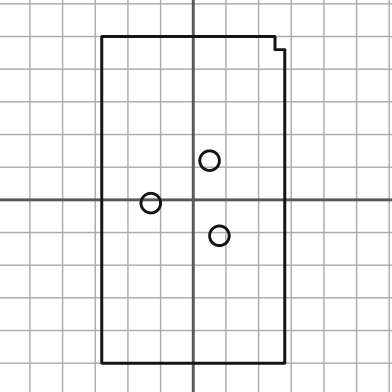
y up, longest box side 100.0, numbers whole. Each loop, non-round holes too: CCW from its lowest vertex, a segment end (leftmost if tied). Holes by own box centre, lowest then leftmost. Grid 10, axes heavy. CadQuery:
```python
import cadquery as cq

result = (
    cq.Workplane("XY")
    .moveTo(-28.0, -50.0)
    .lineTo(28.0, -50.0)
    .lineTo(28.0, 46.0)
    .lineTo(25.0, 46.0)
    .lineTo(25.0, 50.0)
    .lineTo(-28.0, 50.0)
    .close()
    .moveTo(8.0, -11.0)
    .circle(3.0)
    .moveTo(-13.0, -1.0)
    .circle(3.0)
    .moveTo(5.0, 12.0)
    .circle(3.0)
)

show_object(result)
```